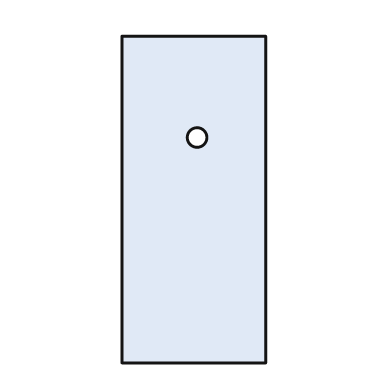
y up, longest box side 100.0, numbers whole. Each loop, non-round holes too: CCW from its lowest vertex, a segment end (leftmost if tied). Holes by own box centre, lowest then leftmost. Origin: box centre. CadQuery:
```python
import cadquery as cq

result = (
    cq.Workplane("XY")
    .moveTo(-22.0, -50.0)
    .lineTo(22.0, -50.0)
    .lineTo(22.0, 50.0)
    .lineTo(-22.0, 50.0)
    .close()
    .moveTo(1.0, 19.0)
    .circle(3.0)
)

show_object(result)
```